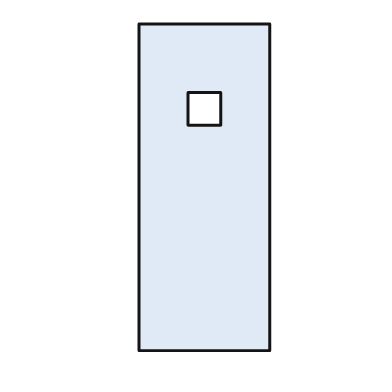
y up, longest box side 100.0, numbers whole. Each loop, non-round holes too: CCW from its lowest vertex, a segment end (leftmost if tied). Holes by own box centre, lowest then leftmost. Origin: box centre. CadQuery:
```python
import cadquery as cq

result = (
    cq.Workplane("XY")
    .moveTo(-20.0, -50.0)
    .lineTo(20.0, -50.0)
    .lineTo(20.0, 50.0)
    .lineTo(-20.0, 50.0)
    .close()
    .moveTo(-5.0, 19.0)
    .lineTo(5.0, 19.0)
    .lineTo(5.0, 29.0)
    .lineTo(-5.0, 29.0)
    .close()
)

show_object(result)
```